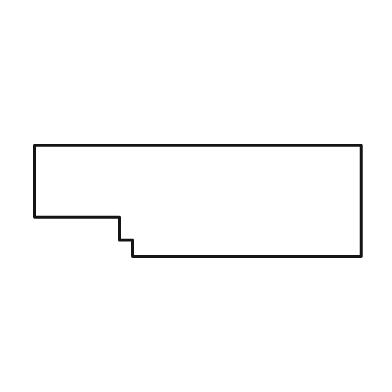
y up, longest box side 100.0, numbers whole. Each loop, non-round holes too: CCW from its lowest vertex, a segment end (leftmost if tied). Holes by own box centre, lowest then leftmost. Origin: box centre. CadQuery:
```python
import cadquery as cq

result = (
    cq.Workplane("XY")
    .moveTo(-20.0, -17.0)
    .lineTo(50.0, -17.0)
    .lineTo(50.0, 17.0)
    .lineTo(-50.0, 17.0)
    .lineTo(-50.0, -5.0)
    .lineTo(-24.0, -5.0)
    .lineTo(-24.0, -12.0)
    .lineTo(-20.0, -12.0)
    .close()
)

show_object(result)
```